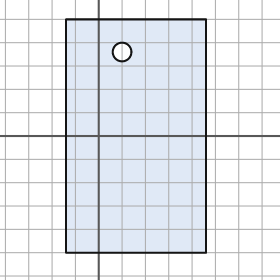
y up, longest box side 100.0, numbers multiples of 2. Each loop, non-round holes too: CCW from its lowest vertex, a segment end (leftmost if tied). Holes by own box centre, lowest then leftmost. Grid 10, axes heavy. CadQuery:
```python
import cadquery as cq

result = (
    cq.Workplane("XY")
    .moveTo(-14.0, -50.0)
    .lineTo(46.0, -50.0)
    .lineTo(46.0, 50.0)
    .lineTo(-14.0, 50.0)
    .close()
    .moveTo(10.0, 36.0)
    .circle(4.0)
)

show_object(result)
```